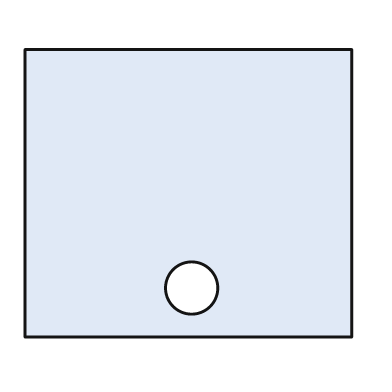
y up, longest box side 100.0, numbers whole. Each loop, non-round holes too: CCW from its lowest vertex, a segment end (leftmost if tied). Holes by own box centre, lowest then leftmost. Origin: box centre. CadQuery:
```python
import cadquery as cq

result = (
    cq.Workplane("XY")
    .moveTo(-50.0, -44.0)
    .lineTo(50.0, -44.0)
    .lineTo(50.0, 44.0)
    .lineTo(-50.0, 44.0)
    .close()
    .moveTo(1.0, -29.0)
    .circle(8.0)
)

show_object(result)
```